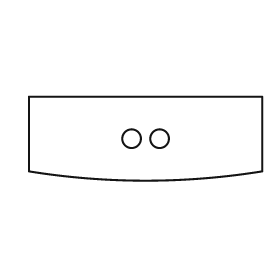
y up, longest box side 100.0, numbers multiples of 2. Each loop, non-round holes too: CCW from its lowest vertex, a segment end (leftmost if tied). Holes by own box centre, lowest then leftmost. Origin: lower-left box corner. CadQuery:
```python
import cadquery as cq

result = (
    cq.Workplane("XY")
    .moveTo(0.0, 4.0)
    .threePointArc((50.0, 0.0), (100.0, 4.0))
    .lineTo(100.0, 36.0)
    .lineTo(0.0, 36.0)
    .close()
    .moveTo(44.0, 18.0)
    .circle(4.0)
    .moveTo(56.0, 18.0)
    .circle(4.0)
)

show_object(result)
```